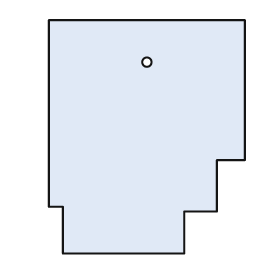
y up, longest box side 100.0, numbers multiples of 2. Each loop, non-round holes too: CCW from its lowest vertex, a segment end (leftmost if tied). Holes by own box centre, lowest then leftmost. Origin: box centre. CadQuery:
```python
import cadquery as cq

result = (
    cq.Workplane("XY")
    .moveTo(-36.0, -50.0)
    .lineTo(16.0, -50.0)
    .lineTo(16.0, -32.0)
    .lineTo(30.0, -32.0)
    .lineTo(30.0, -10.0)
    .lineTo(42.0, -10.0)
    .lineTo(42.0, 50.0)
    .lineTo(-42.0, 50.0)
    .lineTo(-42.0, -30.0)
    .lineTo(-36.0, -30.0)
    .close()
    .moveTo(0.0, 32.0)
    .circle(2.0)
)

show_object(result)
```